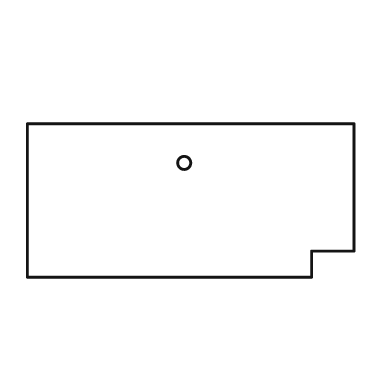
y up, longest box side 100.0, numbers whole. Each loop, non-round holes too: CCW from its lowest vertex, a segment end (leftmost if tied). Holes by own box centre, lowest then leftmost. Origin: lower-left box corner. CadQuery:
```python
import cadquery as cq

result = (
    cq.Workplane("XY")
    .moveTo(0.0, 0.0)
    .lineTo(87.0, 0.0)
    .lineTo(87.0, 8.0)
    .lineTo(100.0, 8.0)
    .lineTo(100.0, 47.0)
    .lineTo(0.0, 47.0)
    .close()
    .moveTo(48.0, 35.0)
    .circle(2.0)
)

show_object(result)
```